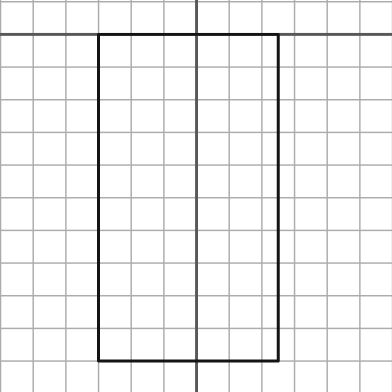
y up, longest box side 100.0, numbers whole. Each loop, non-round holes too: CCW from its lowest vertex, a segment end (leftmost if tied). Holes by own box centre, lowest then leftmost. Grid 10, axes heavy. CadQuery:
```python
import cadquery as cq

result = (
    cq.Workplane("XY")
    .moveTo(-30.0, -100.0)
    .lineTo(25.0, -100.0)
    .lineTo(25.0, 0.0)
    .lineTo(-30.0, 0.0)
    .close()
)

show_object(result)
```